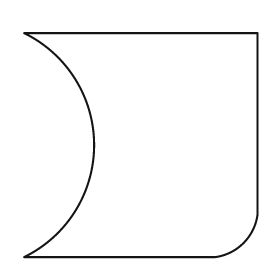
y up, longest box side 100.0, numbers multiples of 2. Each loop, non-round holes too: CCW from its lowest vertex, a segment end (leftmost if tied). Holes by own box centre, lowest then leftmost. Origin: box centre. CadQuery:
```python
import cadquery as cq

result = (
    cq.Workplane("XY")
    .moveTo(-50.0, -48.0)
    .lineTo(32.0, -48.0)
    .threePointArc((44.0, -42.0), (50.0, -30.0))
    .lineTo(50.0, 48.0)
    .lineTo(-50.0, 48.0)
    .threePointArc((-20.0, 0.0), (-50.0, -48.0))
    .close()
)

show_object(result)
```